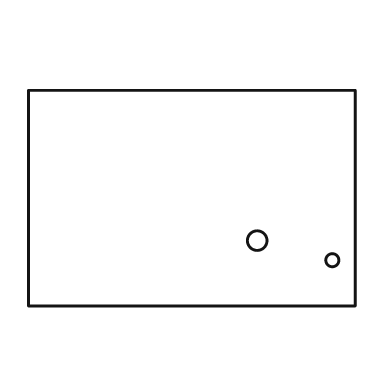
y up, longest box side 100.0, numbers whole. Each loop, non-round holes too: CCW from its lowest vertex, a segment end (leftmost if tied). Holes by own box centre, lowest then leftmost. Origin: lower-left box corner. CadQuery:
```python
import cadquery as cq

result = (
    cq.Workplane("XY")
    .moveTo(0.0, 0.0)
    .lineTo(100.0, 0.0)
    .lineTo(100.0, 66.0)
    .lineTo(0.0, 66.0)
    .close()
    .moveTo(93.0, 14.0)
    .circle(2.0)
    .moveTo(70.0, 20.0)
    .circle(3.0)
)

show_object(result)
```